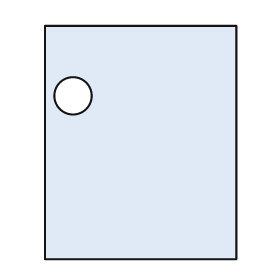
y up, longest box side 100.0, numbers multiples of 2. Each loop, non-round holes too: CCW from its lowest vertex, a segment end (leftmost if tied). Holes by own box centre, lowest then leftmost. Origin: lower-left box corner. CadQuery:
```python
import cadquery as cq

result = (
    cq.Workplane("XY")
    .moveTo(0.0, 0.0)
    .lineTo(82.0, 0.0)
    .lineTo(82.0, 100.0)
    .lineTo(0.0, 100.0)
    .close()
    .moveTo(12.0, 70.0)
    .circle(8.0)
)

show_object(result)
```